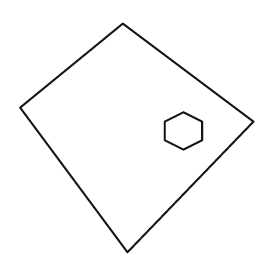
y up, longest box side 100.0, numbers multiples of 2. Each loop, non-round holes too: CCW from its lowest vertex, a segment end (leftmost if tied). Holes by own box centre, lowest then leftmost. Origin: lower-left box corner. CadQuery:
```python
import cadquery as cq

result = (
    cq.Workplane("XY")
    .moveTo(46.0, 0.0)
    .lineTo(100.0, 56.0)
    .lineTo(44.0, 98.0)
    .lineTo(0.0, 62.0)
    .close()
    .moveTo(70.0, 44.0)
    .lineTo(78.0, 48.0)
    .lineTo(78.0, 56.0)
    .lineTo(70.0, 60.0)
    .lineTo(62.0, 56.0)
    .lineTo(62.0, 48.0)
    .close()
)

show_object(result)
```